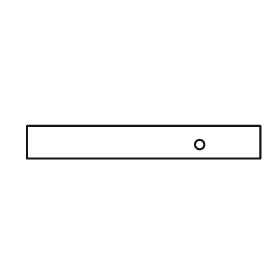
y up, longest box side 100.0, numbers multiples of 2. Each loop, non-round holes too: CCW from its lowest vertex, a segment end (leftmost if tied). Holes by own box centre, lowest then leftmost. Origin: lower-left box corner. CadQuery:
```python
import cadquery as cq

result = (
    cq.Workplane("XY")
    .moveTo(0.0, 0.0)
    .lineTo(100.0, 0.0)
    .lineTo(100.0, 14.0)
    .lineTo(0.0, 14.0)
    .close()
    .moveTo(74.0, 6.0)
    .circle(2.0)
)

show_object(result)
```